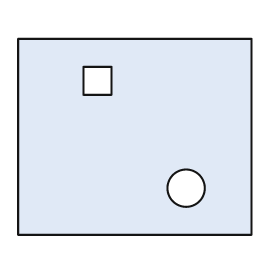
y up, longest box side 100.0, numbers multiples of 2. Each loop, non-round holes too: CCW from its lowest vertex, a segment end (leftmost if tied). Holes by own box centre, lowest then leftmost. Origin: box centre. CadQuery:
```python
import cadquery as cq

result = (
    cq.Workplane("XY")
    .moveTo(-50.0, -42.0)
    .lineTo(50.0, -42.0)
    .lineTo(50.0, 42.0)
    .lineTo(-50.0, 42.0)
    .close()
    .moveTo(22.0, -22.0)
    .circle(8.0)
    .moveTo(-22.0, 18.0)
    .lineTo(-10.0, 18.0)
    .lineTo(-10.0, 30.0)
    .lineTo(-22.0, 30.0)
    .close()
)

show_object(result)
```